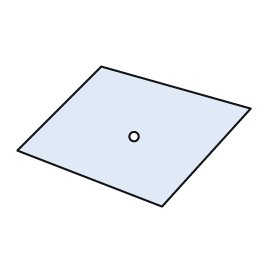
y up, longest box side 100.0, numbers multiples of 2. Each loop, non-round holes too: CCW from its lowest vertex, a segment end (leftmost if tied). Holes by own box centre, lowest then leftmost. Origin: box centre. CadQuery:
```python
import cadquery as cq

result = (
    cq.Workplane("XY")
    .moveTo(12.0, -30.0)
    .lineTo(50.0, 12.0)
    .lineTo(-14.0, 30.0)
    .lineTo(-50.0, -6.0)
    .close()
    .moveTo(0.0, 0.0)
    .circle(2.0)
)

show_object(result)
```